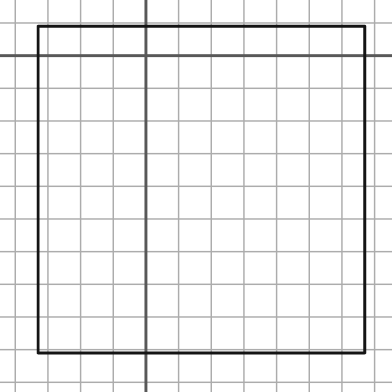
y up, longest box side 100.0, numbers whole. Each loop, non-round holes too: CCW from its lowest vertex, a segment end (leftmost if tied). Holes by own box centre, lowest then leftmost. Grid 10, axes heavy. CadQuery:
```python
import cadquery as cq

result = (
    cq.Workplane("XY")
    .moveTo(-33.0, -91.0)
    .lineTo(67.0, -91.0)
    .lineTo(67.0, 9.0)
    .lineTo(-33.0, 9.0)
    .close()
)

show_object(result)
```